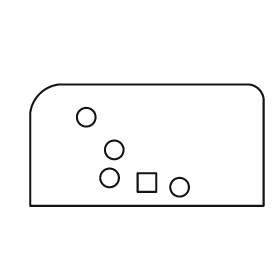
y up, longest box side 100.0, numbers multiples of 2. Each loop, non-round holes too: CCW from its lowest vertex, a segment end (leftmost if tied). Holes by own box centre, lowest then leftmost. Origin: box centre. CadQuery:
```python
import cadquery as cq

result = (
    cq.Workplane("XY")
    .moveTo(-50.0, -26.0)
    .lineTo(50.0, -26.0)
    .lineTo(50.0, 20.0)
    .threePointArc((48.0, 24.0), (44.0, 26.0))
    .lineTo(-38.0, 26.0)
    .threePointArc((-46.0, 22.0), (-50.0, 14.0))
    .close()
    .moveTo(14.0, -18.0)
    .circle(4.0)
    .moveTo(-4.0, -20.0)
    .lineTo(4.0, -20.0)
    .lineTo(4.0, -12.0)
    .lineTo(-4.0, -12.0)
    .close()
    .moveTo(-16.0, -14.0)
    .circle(4.0)
    .moveTo(-14.0, -2.0)
    .circle(4.0)
    .moveTo(-26.0, 12.0)
    .circle(4.0)
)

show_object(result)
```